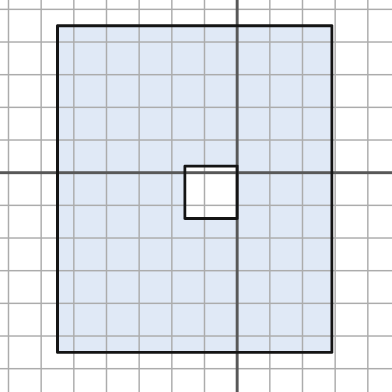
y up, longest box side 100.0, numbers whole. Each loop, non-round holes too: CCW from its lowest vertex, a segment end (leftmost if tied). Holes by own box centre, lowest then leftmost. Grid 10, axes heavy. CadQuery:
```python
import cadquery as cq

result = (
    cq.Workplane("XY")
    .moveTo(-55.0, -55.0)
    .lineTo(29.0, -55.0)
    .lineTo(29.0, 45.0)
    .lineTo(-55.0, 45.0)
    .close()
    .moveTo(-16.0, -14.0)
    .lineTo(0.0, -14.0)
    .lineTo(0.0, 2.0)
    .lineTo(-16.0, 2.0)
    .close()
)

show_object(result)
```